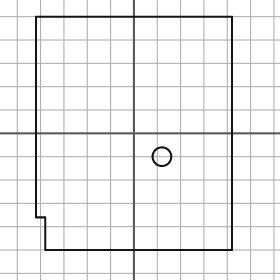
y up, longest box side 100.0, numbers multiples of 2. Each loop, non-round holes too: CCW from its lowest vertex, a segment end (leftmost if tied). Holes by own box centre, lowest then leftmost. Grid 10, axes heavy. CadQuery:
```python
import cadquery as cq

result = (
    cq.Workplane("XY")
    .moveTo(-38.0, -50.0)
    .lineTo(42.0, -50.0)
    .lineTo(42.0, 50.0)
    .lineTo(-42.0, 50.0)
    .lineTo(-42.0, -36.0)
    .lineTo(-38.0, -36.0)
    .close()
    .moveTo(12.0, -10.0)
    .circle(4.0)
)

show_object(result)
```